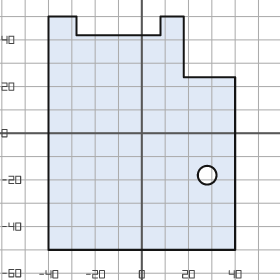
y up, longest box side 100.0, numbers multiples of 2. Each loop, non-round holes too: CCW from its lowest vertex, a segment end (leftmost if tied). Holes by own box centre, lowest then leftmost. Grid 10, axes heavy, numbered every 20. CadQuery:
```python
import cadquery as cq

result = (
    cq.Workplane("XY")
    .moveTo(-40.0, -50.0)
    .lineTo(40.0, -50.0)
    .lineTo(40.0, 24.0)
    .lineTo(18.0, 24.0)
    .lineTo(18.0, 50.0)
    .lineTo(8.0, 50.0)
    .lineTo(8.0, 42.0)
    .lineTo(-28.0, 42.0)
    .lineTo(-28.0, 50.0)
    .lineTo(-40.0, 50.0)
    .close()
    .moveTo(28.0, -18.0)
    .circle(4.0)
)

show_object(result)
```